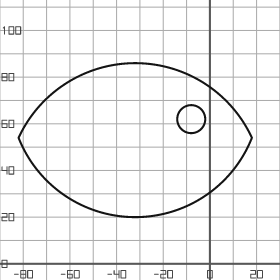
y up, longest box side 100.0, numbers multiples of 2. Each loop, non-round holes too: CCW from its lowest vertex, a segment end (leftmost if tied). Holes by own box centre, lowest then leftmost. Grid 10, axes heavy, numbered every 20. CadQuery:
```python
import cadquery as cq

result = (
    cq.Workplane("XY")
    .moveTo(-82.0, 54.0)
    .threePointArc((-32.0, 20.0), (18.0, 54.0))
    .threePointArc((-32.0, 86.0), (-82.0, 54.0))
    .close()
    .moveTo(-8.0, 62.0)
    .circle(6.0)
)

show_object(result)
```